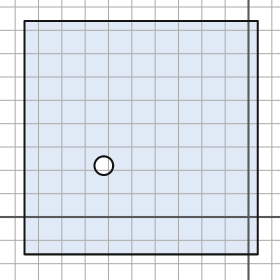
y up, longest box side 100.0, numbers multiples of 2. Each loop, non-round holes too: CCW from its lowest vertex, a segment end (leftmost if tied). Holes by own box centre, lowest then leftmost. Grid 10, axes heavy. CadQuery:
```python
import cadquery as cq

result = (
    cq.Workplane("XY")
    .moveTo(-96.0, -16.0)
    .lineTo(4.0, -16.0)
    .lineTo(4.0, 84.0)
    .lineTo(-96.0, 84.0)
    .close()
    .moveTo(-62.0, 22.0)
    .circle(4.0)
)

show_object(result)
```